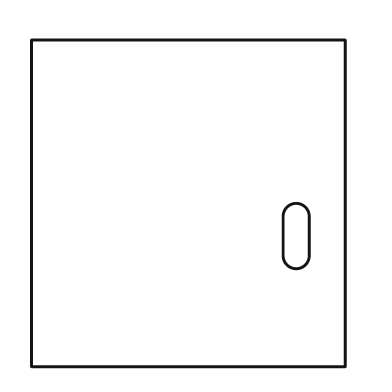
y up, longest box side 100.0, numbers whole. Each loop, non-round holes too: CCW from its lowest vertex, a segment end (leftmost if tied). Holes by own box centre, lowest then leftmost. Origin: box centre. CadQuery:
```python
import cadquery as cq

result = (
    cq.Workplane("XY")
    .moveTo(-48.0, -50.0)
    .lineTo(48.0, -50.0)
    .lineTo(48.0, 50.0)
    .lineTo(-48.0, 50.0)
    .close()
    .moveTo(29.0, -16.0)
    .threePointArc((33.0, -20.0), (37.0, -16.0))
    .lineTo(37.0, -4.0)
    .threePointArc((33.0, 0.0), (29.0, -4.0))
    .close()
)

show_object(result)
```